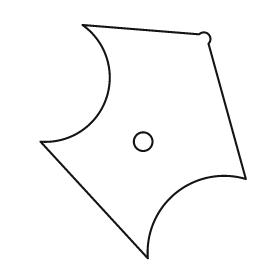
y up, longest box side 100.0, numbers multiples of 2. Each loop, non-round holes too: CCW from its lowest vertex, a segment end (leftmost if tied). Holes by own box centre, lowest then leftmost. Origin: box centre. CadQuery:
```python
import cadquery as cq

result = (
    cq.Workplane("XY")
    .moveTo(2.0, -50.0)
    .threePointArc((14.0, -22.0), (44.0, -16.0))
    .lineTo(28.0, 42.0)
    .threePointArc((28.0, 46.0), (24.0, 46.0))
    .lineTo(-26.0, 50.0)
    .threePointArc((-16.0, 18.0), (-44.0, 0.0))
    .close()
    .moveTo(0.0, 0.0)
    .circle(4.0)
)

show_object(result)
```